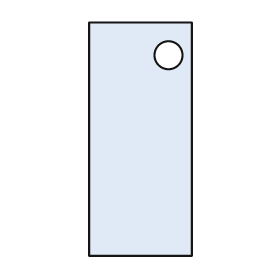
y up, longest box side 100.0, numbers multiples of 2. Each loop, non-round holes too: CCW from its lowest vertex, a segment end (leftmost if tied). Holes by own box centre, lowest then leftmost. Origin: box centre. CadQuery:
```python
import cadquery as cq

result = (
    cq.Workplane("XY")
    .moveTo(-22.0, -50.0)
    .lineTo(22.0, -50.0)
    .lineTo(22.0, 50.0)
    .lineTo(-22.0, 50.0)
    .close()
    .moveTo(12.0, 36.0)
    .circle(6.0)
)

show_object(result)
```